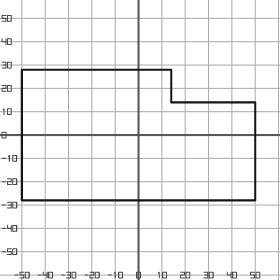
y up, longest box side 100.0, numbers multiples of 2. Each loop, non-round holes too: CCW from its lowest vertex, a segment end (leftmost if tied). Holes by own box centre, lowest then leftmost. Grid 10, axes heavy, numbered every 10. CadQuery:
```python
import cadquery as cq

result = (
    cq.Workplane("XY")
    .moveTo(-50.0, -28.0)
    .lineTo(50.0, -28.0)
    .lineTo(50.0, 14.0)
    .lineTo(14.0, 14.0)
    .lineTo(14.0, 28.0)
    .lineTo(-50.0, 28.0)
    .close()
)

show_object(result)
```